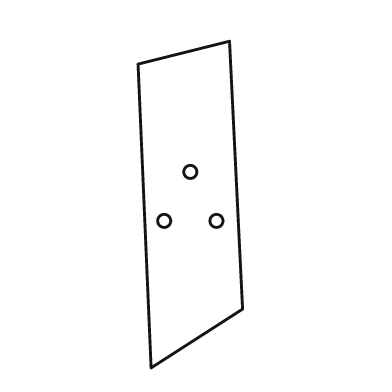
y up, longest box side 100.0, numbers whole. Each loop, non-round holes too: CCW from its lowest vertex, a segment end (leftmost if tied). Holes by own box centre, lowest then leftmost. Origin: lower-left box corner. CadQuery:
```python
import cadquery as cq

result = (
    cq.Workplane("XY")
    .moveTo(4.0, 0.0)
    .lineTo(32.0, 18.0)
    .lineTo(28.0, 100.0)
    .lineTo(0.0, 93.0)
    .close()
    .moveTo(8.0, 45.0)
    .circle(2.0)
    .moveTo(24.0, 45.0)
    .circle(2.0)
    .moveTo(16.0, 60.0)
    .circle(2.0)
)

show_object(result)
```